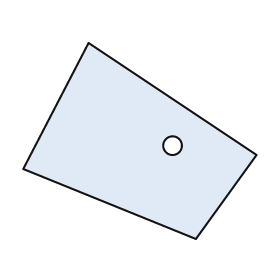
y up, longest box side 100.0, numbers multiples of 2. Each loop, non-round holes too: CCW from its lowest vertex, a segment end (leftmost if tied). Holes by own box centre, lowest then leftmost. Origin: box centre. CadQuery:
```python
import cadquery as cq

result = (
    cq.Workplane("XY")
    .moveTo(24.0, -42.0)
    .lineTo(50.0, -6.0)
    .lineTo(-22.0, 42.0)
    .lineTo(-50.0, -12.0)
    .close()
    .moveTo(14.0, -2.0)
    .circle(4.0)
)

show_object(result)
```